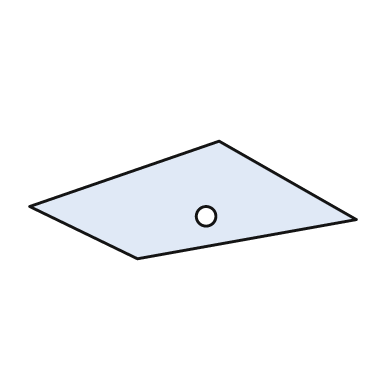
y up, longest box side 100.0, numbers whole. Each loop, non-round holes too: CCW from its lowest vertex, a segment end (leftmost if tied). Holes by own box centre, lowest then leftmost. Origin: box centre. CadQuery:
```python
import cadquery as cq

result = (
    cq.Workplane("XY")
    .moveTo(-17.0, -18.0)
    .lineTo(50.0, -6.0)
    .lineTo(8.0, 18.0)
    .lineTo(-50.0, -2.0)
    .close()
    .moveTo(4.0, -5.0)
    .circle(3.0)
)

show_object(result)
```